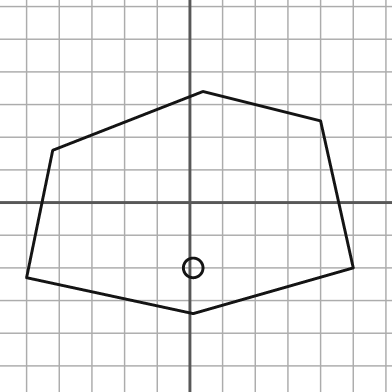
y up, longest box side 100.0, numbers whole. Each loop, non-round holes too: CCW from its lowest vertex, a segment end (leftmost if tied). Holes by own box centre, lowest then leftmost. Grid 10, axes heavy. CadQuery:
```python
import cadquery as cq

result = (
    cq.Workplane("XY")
    .moveTo(1.0, -34.0)
    .lineTo(50.0, -20.0)
    .lineTo(40.0, 25.0)
    .lineTo(4.0, 34.0)
    .lineTo(-42.0, 16.0)
    .lineTo(-50.0, -23.0)
    .close()
    .moveTo(1.0, -20.0)
    .circle(3.0)
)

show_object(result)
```